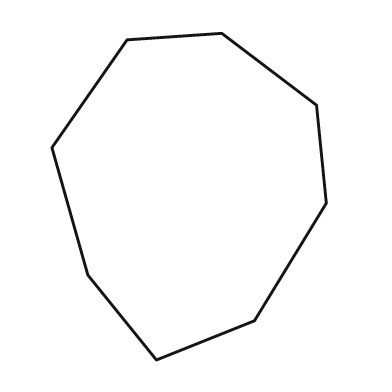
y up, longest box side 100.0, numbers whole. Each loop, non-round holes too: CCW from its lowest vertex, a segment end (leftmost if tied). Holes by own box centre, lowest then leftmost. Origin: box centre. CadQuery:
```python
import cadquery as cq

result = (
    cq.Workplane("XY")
    .moveTo(-10.0, -50.0)
    .lineTo(20.0, -38.0)
    .lineTo(42.0, -2.0)
    .lineTo(39.0, 28.0)
    .lineTo(10.0, 50.0)
    .lineTo(-19.0, 48.0)
    .lineTo(-42.0, 15.0)
    .lineTo(-31.0, -24.0)
    .close()
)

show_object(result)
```